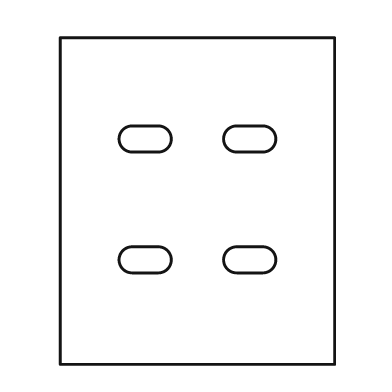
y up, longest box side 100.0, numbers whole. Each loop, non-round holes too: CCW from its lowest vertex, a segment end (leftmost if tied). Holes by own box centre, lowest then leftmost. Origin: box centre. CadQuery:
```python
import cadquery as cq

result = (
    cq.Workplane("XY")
    .moveTo(-42.0, -50.0)
    .lineTo(42.0, -50.0)
    .lineTo(42.0, 50.0)
    .lineTo(-42.0, 50.0)
    .close()
    .moveTo(-20.0, -22.0)
    .lineTo(-12.0, -22.0)
    .threePointArc((-8.0, -18.0), (-12.0, -14.0))
    .lineTo(-20.0, -14.0)
    .threePointArc((-24.0, -18.0), (-20.0, -22.0))
    .close()
    .moveTo(12.0, -22.0)
    .lineTo(20.0, -22.0)
    .threePointArc((24.0, -18.0), (20.0, -14.0))
    .lineTo(12.0, -14.0)
    .threePointArc((8.0, -18.0), (12.0, -22.0))
    .close()
    .moveTo(-20.0, 15.0)
    .lineTo(-12.0, 15.0)
    .threePointArc((-8.0, 19.0), (-12.0, 23.0))
    .lineTo(-20.0, 23.0)
    .threePointArc((-24.0, 19.0), (-20.0, 15.0))
    .close()
    .moveTo(12.0, 15.0)
    .lineTo(20.0, 15.0)
    .threePointArc((24.0, 19.0), (20.0, 23.0))
    .lineTo(12.0, 23.0)
    .threePointArc((8.0, 19.0), (12.0, 15.0))
    .close()
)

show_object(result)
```